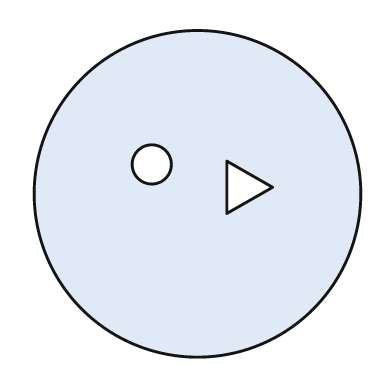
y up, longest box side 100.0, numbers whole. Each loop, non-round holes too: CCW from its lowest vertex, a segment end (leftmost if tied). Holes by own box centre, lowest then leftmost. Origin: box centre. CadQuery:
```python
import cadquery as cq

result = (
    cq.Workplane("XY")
    .moveTo(0.0, 0.0)
    .circle(50.0)
    .moveTo(9.0, -6.0)
    .lineTo(23.0, 2.0)
    .lineTo(9.0, 10.0)
    .close()
    .moveTo(-14.0, 9.0)
    .circle(6.0)
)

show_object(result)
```